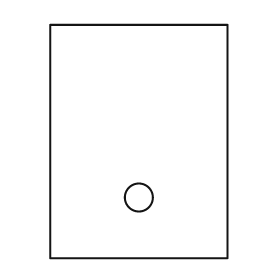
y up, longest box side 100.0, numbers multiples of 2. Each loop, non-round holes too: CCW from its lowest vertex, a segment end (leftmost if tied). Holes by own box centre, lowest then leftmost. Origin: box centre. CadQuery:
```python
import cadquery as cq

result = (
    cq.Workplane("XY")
    .moveTo(-38.0, -50.0)
    .lineTo(38.0, -50.0)
    .lineTo(38.0, 50.0)
    .lineTo(-38.0, 50.0)
    .close()
    .moveTo(0.0, -24.0)
    .circle(6.0)
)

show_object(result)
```